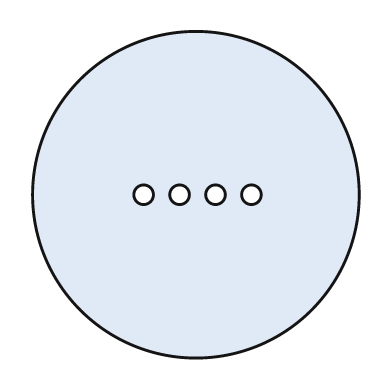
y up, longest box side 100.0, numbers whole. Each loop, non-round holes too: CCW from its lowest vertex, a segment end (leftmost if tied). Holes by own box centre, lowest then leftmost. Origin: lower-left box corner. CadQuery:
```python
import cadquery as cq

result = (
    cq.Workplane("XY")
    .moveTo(50.0, 50.0)
    .circle(50.0)
    .moveTo(34.0, 50.0)
    .circle(3.0)
    .moveTo(45.0, 50.0)
    .circle(3.0)
    .moveTo(56.0, 50.0)
    .circle(3.0)
    .moveTo(67.0, 50.0)
    .circle(3.0)
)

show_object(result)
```